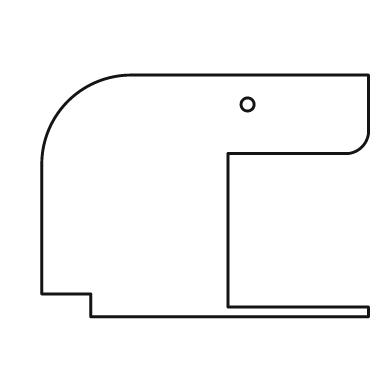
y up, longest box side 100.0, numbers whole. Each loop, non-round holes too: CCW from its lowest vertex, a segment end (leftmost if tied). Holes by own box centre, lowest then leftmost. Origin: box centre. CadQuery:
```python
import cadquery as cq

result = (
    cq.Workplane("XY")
    .moveTo(-35.0, -37.0)
    .lineTo(50.0, -37.0)
    .lineTo(50.0, -34.0)
    .lineTo(7.0, -34.0)
    .lineTo(7.0, 13.0)
    .lineTo(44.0, 13.0)
    .threePointArc((48.0, 15.0), (50.0, 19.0))
    .lineTo(50.0, 37.0)
    .lineTo(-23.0, 37.0)
    .threePointArc((-42.0, 29.0), (-50.0, 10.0))
    .lineTo(-50.0, -30.0)
    .lineTo(-35.0, -30.0)
    .close()
    .moveTo(13.0, 28.0)
    .circle(2.0)
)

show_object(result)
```